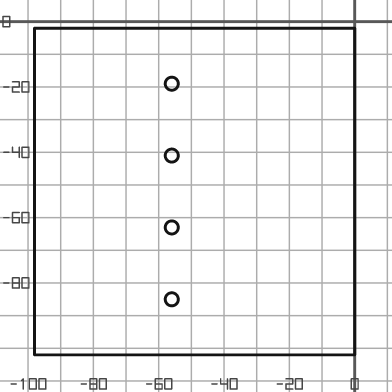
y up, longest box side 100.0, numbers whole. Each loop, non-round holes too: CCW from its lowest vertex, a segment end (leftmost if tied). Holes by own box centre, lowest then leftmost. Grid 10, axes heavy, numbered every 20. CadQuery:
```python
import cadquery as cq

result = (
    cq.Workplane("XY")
    .moveTo(-98.0, -102.0)
    .lineTo(0.0, -102.0)
    .lineTo(0.0, -2.0)
    .lineTo(-98.0, -2.0)
    .close()
    .moveTo(-56.0, -85.0)
    .circle(2.0)
    .moveTo(-56.0, -63.0)
    .circle(2.0)
    .moveTo(-56.0, -41.0)
    .circle(2.0)
    .moveTo(-56.0, -19.0)
    .circle(2.0)
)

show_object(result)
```